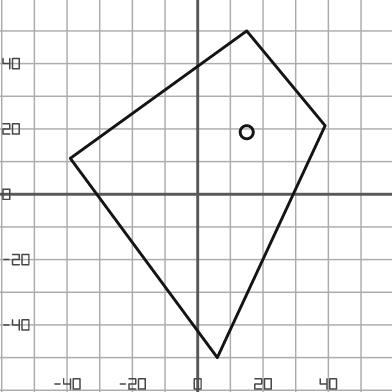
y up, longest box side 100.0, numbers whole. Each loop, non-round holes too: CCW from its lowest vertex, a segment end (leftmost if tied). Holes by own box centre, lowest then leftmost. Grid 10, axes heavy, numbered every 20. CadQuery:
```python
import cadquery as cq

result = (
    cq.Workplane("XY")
    .moveTo(6.0, -50.0)
    .lineTo(39.0, 21.0)
    .lineTo(15.0, 50.0)
    .lineTo(-39.0, 11.0)
    .close()
    .moveTo(15.0, 19.0)
    .circle(2.0)
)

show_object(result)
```